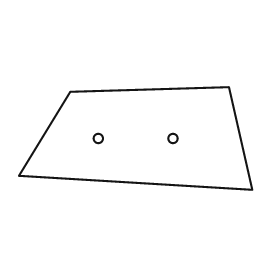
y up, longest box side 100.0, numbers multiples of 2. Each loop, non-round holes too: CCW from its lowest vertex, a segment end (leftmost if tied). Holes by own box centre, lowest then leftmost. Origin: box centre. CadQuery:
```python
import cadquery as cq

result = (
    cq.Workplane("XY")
    .moveTo(50.0, -22.0)
    .lineTo(40.0, 22.0)
    .lineTo(-28.0, 20.0)
    .lineTo(-50.0, -16.0)
    .close()
    .moveTo(-16.0, 0.0)
    .circle(2.0)
    .moveTo(16.0, 0.0)
    .circle(2.0)
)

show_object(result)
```